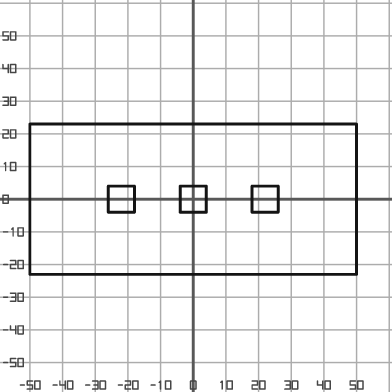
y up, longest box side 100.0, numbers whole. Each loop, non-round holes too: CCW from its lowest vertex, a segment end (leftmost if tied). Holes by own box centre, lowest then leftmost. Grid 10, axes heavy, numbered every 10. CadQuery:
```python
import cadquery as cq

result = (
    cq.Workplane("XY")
    .moveTo(-50.0, -23.0)
    .lineTo(50.0, -23.0)
    .lineTo(50.0, 23.0)
    .lineTo(-50.0, 23.0)
    .close()
    .moveTo(-26.0, -4.0)
    .lineTo(-18.0, -4.0)
    .lineTo(-18.0, 4.0)
    .lineTo(-26.0, 4.0)
    .close()
    .moveTo(-4.0, -4.0)
    .lineTo(4.0, -4.0)
    .lineTo(4.0, 4.0)
    .lineTo(-4.0, 4.0)
    .close()
    .moveTo(18.0, -4.0)
    .lineTo(26.0, -4.0)
    .lineTo(26.0, 4.0)
    .lineTo(18.0, 4.0)
    .close()
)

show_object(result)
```